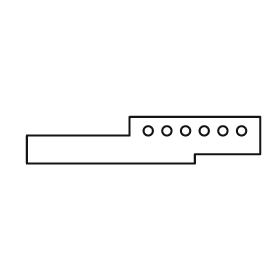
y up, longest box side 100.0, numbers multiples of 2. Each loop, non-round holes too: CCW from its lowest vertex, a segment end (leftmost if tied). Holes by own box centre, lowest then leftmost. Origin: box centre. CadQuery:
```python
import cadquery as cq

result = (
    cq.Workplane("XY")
    .moveTo(-50.0, -10.0)
    .lineTo(22.0, -10.0)
    .lineTo(22.0, -6.0)
    .lineTo(50.0, -6.0)
    .lineTo(50.0, 10.0)
    .lineTo(-6.0, 10.0)
    .lineTo(-6.0, 2.0)
    .lineTo(-50.0, 2.0)
    .close()
    .moveTo(2.0, 4.0)
    .circle(2.0)
    .moveTo(10.0, 4.0)
    .circle(2.0)
    .moveTo(18.0, 4.0)
    .circle(2.0)
    .moveTo(26.0, 4.0)
    .circle(2.0)
    .moveTo(34.0, 4.0)
    .circle(2.0)
    .moveTo(42.0, 4.0)
    .circle(2.0)
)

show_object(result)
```